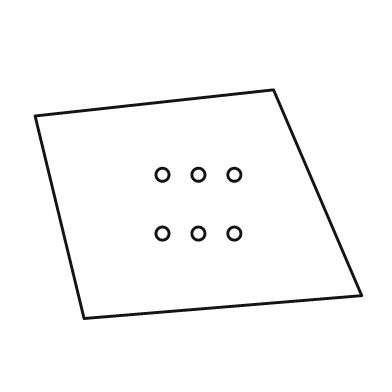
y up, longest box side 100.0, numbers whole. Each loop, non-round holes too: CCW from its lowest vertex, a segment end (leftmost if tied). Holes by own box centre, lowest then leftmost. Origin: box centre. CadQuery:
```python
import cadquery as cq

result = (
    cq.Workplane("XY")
    .moveTo(-35.0, -35.0)
    .lineTo(50.0, -28.0)
    .lineTo(23.0, 35.0)
    .lineTo(-50.0, 27.0)
    .close()
    .moveTo(-11.0, -9.0)
    .circle(2.0)
    .moveTo(0.0, -9.0)
    .circle(2.0)
    .moveTo(11.0, -9.0)
    .circle(2.0)
    .moveTo(-11.0, 9.0)
    .circle(2.0)
    .moveTo(0.0, 9.0)
    .circle(2.0)
    .moveTo(11.0, 9.0)
    .circle(2.0)
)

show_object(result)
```